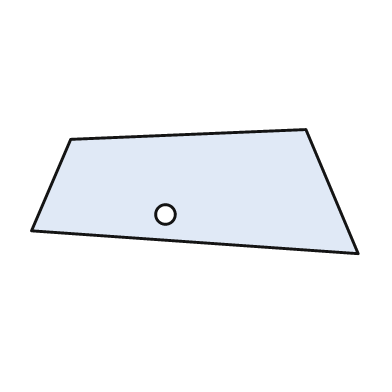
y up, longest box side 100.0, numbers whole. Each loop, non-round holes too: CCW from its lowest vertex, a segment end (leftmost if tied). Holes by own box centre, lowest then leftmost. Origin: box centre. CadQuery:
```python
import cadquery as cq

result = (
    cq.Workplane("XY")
    .moveTo(50.0, -19.0)
    .lineTo(34.0, 19.0)
    .lineTo(-38.0, 16.0)
    .lineTo(-50.0, -12.0)
    .close()
    .moveTo(-9.0, -7.0)
    .circle(3.0)
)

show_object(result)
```